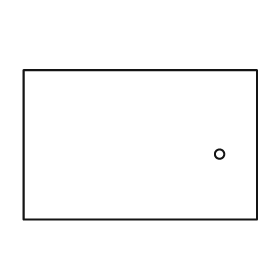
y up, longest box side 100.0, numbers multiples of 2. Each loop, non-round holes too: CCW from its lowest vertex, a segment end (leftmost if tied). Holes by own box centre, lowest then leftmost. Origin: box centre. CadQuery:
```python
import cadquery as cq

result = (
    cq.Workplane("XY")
    .moveTo(-50.0, -32.0)
    .lineTo(50.0, -32.0)
    .lineTo(50.0, 32.0)
    .lineTo(-50.0, 32.0)
    .close()
    .moveTo(34.0, -4.0)
    .circle(2.0)
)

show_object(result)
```